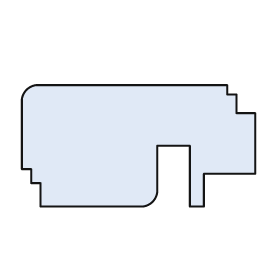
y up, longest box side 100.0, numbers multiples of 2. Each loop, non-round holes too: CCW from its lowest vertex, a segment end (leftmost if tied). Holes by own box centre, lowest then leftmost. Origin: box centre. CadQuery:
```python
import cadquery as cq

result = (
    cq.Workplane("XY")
    .moveTo(-42.0, -26.0)
    .lineTo(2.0, -26.0)
    .threePointArc((6.0, -24.0), (8.0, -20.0))
    .lineTo(8.0, 0.0)
    .lineTo(22.0, 0.0)
    .lineTo(22.0, -26.0)
    .lineTo(28.0, -26.0)
    .lineTo(28.0, -12.0)
    .lineTo(50.0, -12.0)
    .lineTo(50.0, 14.0)
    .lineTo(42.0, 14.0)
    .lineTo(42.0, 22.0)
    .lineTo(38.0, 22.0)
    .lineTo(38.0, 26.0)
    .lineTo(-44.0, 26.0)
    .threePointArc((-48.0, 24.0), (-50.0, 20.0))
    .lineTo(-50.0, -10.0)
    .lineTo(-46.0, -10.0)
    .lineTo(-46.0, -16.0)
    .lineTo(-42.0, -16.0)
    .close()
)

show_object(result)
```